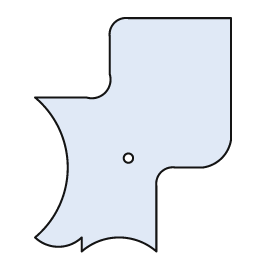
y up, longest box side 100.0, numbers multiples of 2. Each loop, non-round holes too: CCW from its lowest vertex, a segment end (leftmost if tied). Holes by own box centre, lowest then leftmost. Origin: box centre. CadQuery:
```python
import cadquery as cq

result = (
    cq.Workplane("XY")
    .moveTo(-22.0, -50.0)
    .threePointArc((-6.0, -44.0), (10.0, -50.0))
    .lineTo(10.0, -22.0)
    .threePointArc((12.0, -16.0), (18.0, -14.0))
    .lineTo(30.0, -14.0)
    .threePointArc((38.0, -10.0), (42.0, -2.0))
    .lineTo(42.0, 50.0)
    .lineTo(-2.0, 50.0)
    .threePointArc((-8.0, 48.0), (-10.0, 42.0))
    .lineTo(-10.0, 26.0)
    .threePointArc((-12.0, 18.0), (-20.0, 16.0))
    .lineTo(-42.0, 16.0)
    .threePointArc((-28.0, -14.0), (-42.0, -44.0))
    .threePointArc((-32.0, -48.0), (-22.0, -44.0))
    .close()
    .moveTo(-2.0, -10.0)
    .circle(2.0)
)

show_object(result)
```